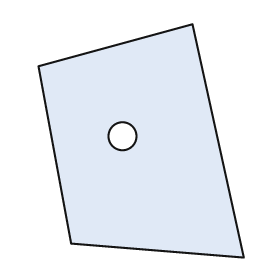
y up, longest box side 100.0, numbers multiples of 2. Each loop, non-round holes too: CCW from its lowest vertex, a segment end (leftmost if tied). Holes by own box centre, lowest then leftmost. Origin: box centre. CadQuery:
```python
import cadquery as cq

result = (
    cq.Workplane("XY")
    .moveTo(44.0, -50.0)
    .lineTo(22.0, 50.0)
    .lineTo(-44.0, 32.0)
    .lineTo(-30.0, -44.0)
    .close()
    .moveTo(-8.0, 2.0)
    .circle(6.0)
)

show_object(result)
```